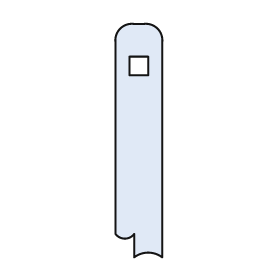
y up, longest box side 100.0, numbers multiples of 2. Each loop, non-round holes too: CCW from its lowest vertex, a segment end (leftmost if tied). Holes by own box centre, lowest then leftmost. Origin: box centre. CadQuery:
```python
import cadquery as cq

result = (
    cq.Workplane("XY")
    .moveTo(-2.0, -50.0)
    .threePointArc((4.0, -48.0), (10.0, -50.0))
    .lineTo(10.0, 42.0)
    .threePointArc((8.0, 48.0), (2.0, 50.0))
    .lineTo(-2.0, 50.0)
    .threePointArc((-8.0, 48.0), (-10.0, 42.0))
    .lineTo(-10.0, -40.0)
    .threePointArc((-6.0, -42.0), (-2.0, -40.0))
    .close()
    .moveTo(-4.0, 28.0)
    .lineTo(4.0, 28.0)
    .lineTo(4.0, 36.0)
    .lineTo(-4.0, 36.0)
    .close()
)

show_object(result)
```